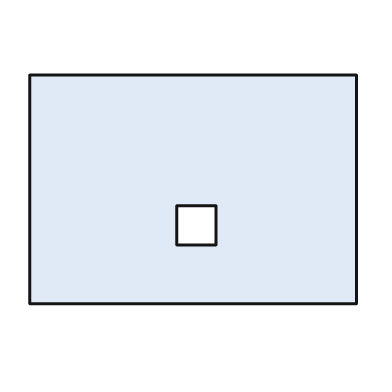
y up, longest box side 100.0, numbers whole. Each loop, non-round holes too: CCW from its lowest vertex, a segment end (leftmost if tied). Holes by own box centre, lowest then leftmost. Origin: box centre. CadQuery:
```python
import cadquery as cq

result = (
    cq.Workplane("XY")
    .moveTo(-50.0, -35.0)
    .lineTo(50.0, -35.0)
    .lineTo(50.0, 35.0)
    .lineTo(-50.0, 35.0)
    .close()
    .moveTo(-5.0, -17.0)
    .lineTo(7.0, -17.0)
    .lineTo(7.0, -5.0)
    .lineTo(-5.0, -5.0)
    .close()
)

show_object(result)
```